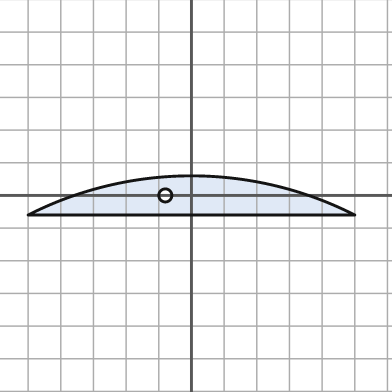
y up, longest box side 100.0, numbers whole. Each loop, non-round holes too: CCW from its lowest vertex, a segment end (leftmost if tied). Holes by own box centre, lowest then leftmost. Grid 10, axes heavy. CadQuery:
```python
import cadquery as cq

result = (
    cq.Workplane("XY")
    .moveTo(-50.0, -6.0)
    .lineTo(50.0, -6.0)
    .threePointArc((0.0, 6.0), (-50.0, -6.0))
    .close()
    .moveTo(-8.0, 0.0)
    .circle(2.0)
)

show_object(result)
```